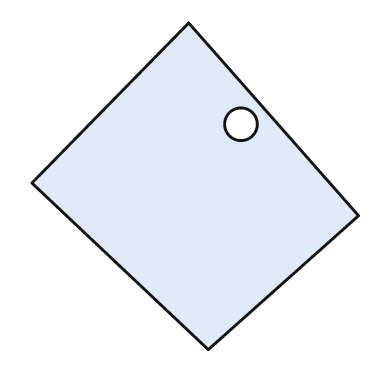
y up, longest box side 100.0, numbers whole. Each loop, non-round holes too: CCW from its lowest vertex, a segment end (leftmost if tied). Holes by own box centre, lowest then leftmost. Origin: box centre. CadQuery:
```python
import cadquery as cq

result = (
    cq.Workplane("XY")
    .moveTo(4.0, -50.0)
    .lineTo(50.0, -9.0)
    .lineTo(-2.0, 50.0)
    .lineTo(-50.0, 1.0)
    .close()
    .moveTo(14.0, 19.0)
    .circle(5.0)
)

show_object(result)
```